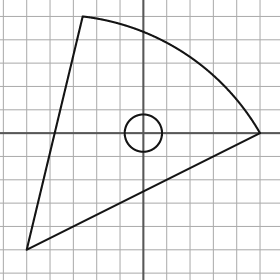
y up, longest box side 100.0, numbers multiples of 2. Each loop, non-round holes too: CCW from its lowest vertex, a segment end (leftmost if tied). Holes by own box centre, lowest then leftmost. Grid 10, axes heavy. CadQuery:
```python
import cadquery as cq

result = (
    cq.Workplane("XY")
    .moveTo(-50.0, -50.0)
    .lineTo(50.0, 0.0)
    .threePointArc((18.0, 34.0), (-26.0, 50.0))
    .close()
    .moveTo(0.0, 0.0)
    .circle(8.0)
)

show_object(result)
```